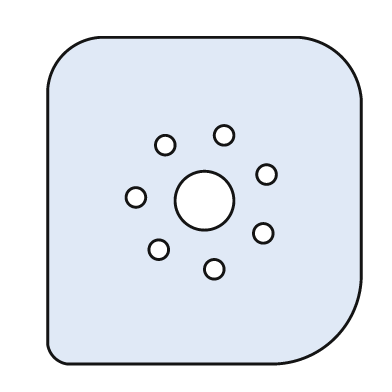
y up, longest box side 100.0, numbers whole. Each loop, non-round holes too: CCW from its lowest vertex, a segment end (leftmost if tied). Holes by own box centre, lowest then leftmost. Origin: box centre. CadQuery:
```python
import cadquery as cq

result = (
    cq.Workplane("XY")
    .moveTo(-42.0, -50.0)
    .lineTo(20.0, -50.0)
    .threePointArc((40.0, -42.0), (48.0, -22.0))
    .lineTo(48.0, 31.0)
    .threePointArc((42.0, 44.0), (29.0, 50.0))
    .lineTo(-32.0, 50.0)
    .threePointArc((-43.0, 45.0), (-48.0, 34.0))
    .lineTo(-48.0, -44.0)
    .threePointArc((-46.0, -48.0), (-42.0, -50.0))
    .close()
    .moveTo(3.0, -21.0)
    .circle(3.0)
    .moveTo(-14.0, -15.0)
    .circle(3.0)
    .moveTo(18.0, -10.0)
    .circle(3.0)
    .moveTo(0.0, 0.0)
    .circle(9.0)
    .moveTo(-21.0, 1.0)
    .circle(3.0)
    .moveTo(19.0, 8.0)
    .circle(3.0)
    .moveTo(-12.0, 17.0)
    .circle(3.0)
    .moveTo(6.0, 20.0)
    .circle(3.0)
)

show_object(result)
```